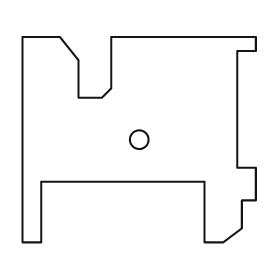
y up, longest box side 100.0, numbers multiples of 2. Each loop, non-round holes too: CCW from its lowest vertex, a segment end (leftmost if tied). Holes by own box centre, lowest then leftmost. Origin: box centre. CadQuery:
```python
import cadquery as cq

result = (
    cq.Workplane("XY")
    .moveTo(-50.0, -44.0)
    .lineTo(-42.0, -44.0)
    .lineTo(-42.0, -18.0)
    .lineTo(28.0, -18.0)
    .lineTo(28.0, -44.0)
    .lineTo(36.0, -44.0)
    .lineTo(44.0, -38.0)
    .lineTo(44.0, -26.0)
    .lineTo(50.0, -26.0)
    .lineTo(50.0, -12.0)
    .lineTo(42.0, -12.0)
    .lineTo(42.0, 38.0)
    .lineTo(50.0, 38.0)
    .lineTo(50.0, 44.0)
    .lineTo(-12.0, 44.0)
    .lineTo(-12.0, 22.0)
    .lineTo(-16.0, 18.0)
    .lineTo(-26.0, 18.0)
    .lineTo(-26.0, 34.0)
    .lineTo(-34.0, 44.0)
    .lineTo(-50.0, 44.0)
    .close()
    .moveTo(0.0, 0.0)
    .circle(4.0)
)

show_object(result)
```